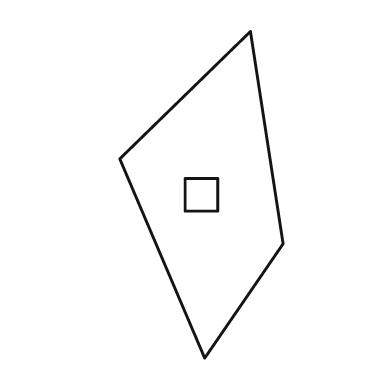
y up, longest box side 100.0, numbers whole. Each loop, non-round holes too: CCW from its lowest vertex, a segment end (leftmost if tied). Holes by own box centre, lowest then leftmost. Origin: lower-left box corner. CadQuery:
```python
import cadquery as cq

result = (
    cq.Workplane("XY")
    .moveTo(26.0, 0.0)
    .lineTo(50.0, 35.0)
    .lineTo(40.0, 100.0)
    .lineTo(0.0, 61.0)
    .close()
    .moveTo(20.0, 45.0)
    .lineTo(30.0, 45.0)
    .lineTo(30.0, 55.0)
    .lineTo(20.0, 55.0)
    .close()
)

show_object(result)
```